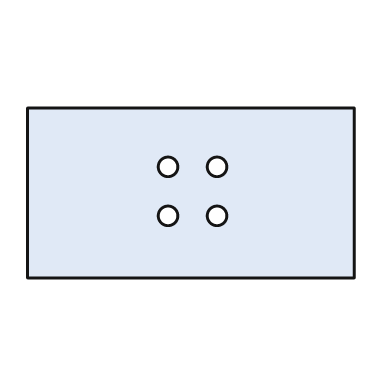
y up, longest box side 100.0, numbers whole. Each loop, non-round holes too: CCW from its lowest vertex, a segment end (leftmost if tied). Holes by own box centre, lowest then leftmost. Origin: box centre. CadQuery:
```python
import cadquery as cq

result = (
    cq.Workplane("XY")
    .moveTo(-50.0, -26.0)
    .lineTo(50.0, -26.0)
    .lineTo(50.0, 26.0)
    .lineTo(-50.0, 26.0)
    .close()
    .moveTo(-7.0, -7.0)
    .circle(3.0)
    .moveTo(8.0, -7.0)
    .circle(3.0)
    .moveTo(-7.0, 8.0)
    .circle(3.0)
    .moveTo(8.0, 8.0)
    .circle(3.0)
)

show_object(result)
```